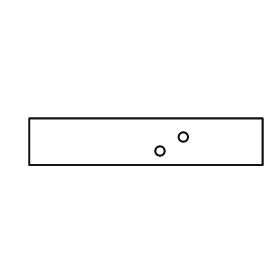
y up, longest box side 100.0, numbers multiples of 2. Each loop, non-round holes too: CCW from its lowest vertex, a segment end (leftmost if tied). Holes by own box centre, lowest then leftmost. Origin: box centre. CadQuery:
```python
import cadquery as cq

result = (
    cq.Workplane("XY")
    .moveTo(-50.0, -10.0)
    .lineTo(50.0, -10.0)
    .lineTo(50.0, 10.0)
    .lineTo(-50.0, 10.0)
    .close()
    .moveTo(6.0, -4.0)
    .circle(2.0)
    .moveTo(16.0, 2.0)
    .circle(2.0)
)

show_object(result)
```